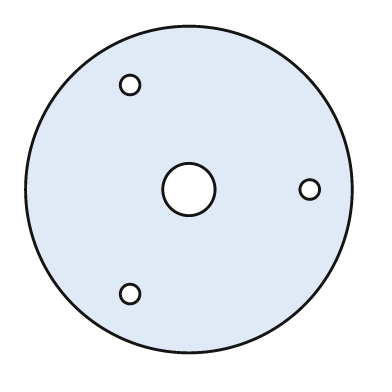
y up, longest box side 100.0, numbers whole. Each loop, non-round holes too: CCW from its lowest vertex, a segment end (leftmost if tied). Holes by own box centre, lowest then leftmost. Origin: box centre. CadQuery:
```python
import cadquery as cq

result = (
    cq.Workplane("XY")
    .moveTo(0.0, 0.0)
    .circle(50.0)
    .moveTo(-18.0, -32.0)
    .circle(3.0)
    .moveTo(0.0, 0.0)
    .circle(8.0)
    .moveTo(37.0, 0.0)
    .circle(3.0)
    .moveTo(-18.0, 32.0)
    .circle(3.0)
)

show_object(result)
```